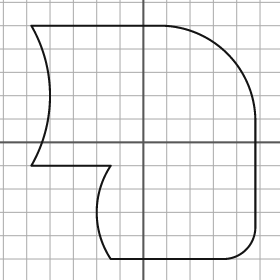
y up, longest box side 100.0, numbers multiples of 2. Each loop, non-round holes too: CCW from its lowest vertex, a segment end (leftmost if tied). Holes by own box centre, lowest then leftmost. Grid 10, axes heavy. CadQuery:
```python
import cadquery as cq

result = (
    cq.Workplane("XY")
    .moveTo(-14.0, -50.0)
    .lineTo(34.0, -50.0)
    .threePointArc((44.0, -46.0), (48.0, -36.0))
    .lineTo(48.0, 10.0)
    .threePointArc((36.0, 38.0), (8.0, 50.0))
    .lineTo(-48.0, 50.0)
    .threePointArc((-40.0, 20.0), (-48.0, -10.0))
    .lineTo(-14.0, -10.0)
    .threePointArc((-20.0, -30.0), (-14.0, -50.0))
    .close()
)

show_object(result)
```